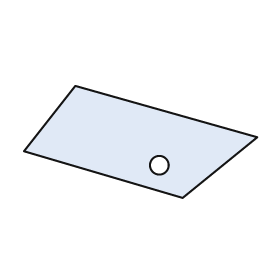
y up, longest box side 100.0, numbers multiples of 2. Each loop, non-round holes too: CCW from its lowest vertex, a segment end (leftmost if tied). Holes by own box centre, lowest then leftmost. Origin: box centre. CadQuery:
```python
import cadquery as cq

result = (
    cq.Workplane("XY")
    .moveTo(18.0, -24.0)
    .lineTo(50.0, 2.0)
    .lineTo(-28.0, 24.0)
    .lineTo(-50.0, -4.0)
    .close()
    .moveTo(8.0, -10.0)
    .circle(4.0)
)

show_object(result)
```